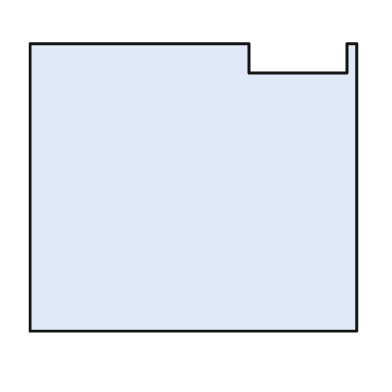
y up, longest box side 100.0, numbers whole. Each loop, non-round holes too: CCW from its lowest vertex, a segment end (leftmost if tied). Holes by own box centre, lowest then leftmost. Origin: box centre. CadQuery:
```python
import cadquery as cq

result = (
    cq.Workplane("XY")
    .moveTo(-50.0, -44.0)
    .lineTo(50.0, -44.0)
    .lineTo(50.0, 44.0)
    .lineTo(47.0, 44.0)
    .lineTo(47.0, 35.0)
    .lineTo(17.0, 35.0)
    .lineTo(17.0, 44.0)
    .lineTo(-50.0, 44.0)
    .close()
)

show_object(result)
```